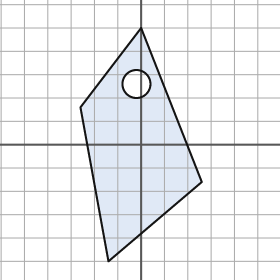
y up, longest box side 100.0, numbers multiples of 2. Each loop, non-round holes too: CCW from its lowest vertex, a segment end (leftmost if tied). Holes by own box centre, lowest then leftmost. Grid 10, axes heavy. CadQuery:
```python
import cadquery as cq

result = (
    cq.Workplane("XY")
    .moveTo(-14.0, -50.0)
    .lineTo(26.0, -16.0)
    .lineTo(0.0, 50.0)
    .lineTo(-26.0, 16.0)
    .close()
    .moveTo(-2.0, 26.0)
    .circle(6.0)
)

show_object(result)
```